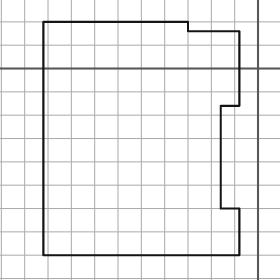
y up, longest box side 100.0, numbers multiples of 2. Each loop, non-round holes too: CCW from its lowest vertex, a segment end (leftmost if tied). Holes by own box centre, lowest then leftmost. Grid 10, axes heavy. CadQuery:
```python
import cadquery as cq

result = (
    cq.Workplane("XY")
    .moveTo(-92.0, -80.0)
    .lineTo(-8.0, -80.0)
    .lineTo(-8.0, -60.0)
    .lineTo(-16.0, -60.0)
    .lineTo(-16.0, -16.0)
    .lineTo(-8.0, -16.0)
    .lineTo(-8.0, 16.0)
    .lineTo(-30.0, 16.0)
    .lineTo(-30.0, 20.0)
    .lineTo(-92.0, 20.0)
    .close()
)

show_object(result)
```